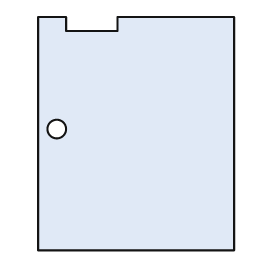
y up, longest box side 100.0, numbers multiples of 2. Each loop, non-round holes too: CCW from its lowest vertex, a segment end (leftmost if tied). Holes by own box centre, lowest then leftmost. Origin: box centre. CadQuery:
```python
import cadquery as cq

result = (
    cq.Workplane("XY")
    .moveTo(-42.0, -50.0)
    .lineTo(42.0, -50.0)
    .lineTo(42.0, 50.0)
    .lineTo(-8.0, 50.0)
    .lineTo(-8.0, 44.0)
    .lineTo(-30.0, 44.0)
    .lineTo(-30.0, 50.0)
    .lineTo(-42.0, 50.0)
    .close()
    .moveTo(-34.0, 2.0)
    .circle(4.0)
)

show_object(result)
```